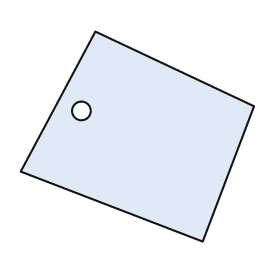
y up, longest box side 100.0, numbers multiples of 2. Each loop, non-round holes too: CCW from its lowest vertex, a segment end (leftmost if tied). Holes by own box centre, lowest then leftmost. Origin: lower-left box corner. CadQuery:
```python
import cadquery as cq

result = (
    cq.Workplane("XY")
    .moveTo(78.0, 0.0)
    .lineTo(100.0, 58.0)
    .lineTo(32.0, 90.0)
    .lineTo(0.0, 30.0)
    .close()
    .moveTo(26.0, 56.0)
    .circle(4.0)
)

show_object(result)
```